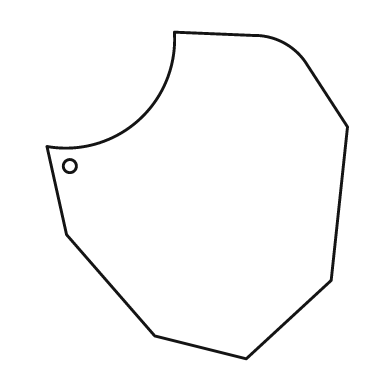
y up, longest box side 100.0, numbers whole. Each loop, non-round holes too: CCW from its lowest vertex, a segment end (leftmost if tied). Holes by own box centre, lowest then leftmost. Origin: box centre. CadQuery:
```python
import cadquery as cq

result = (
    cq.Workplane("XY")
    .moveTo(15.0, -50.0)
    .lineTo(41.0, -26.0)
    .lineTo(46.0, 21.0)
    .lineTo(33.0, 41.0)
    .threePointArc((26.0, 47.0), (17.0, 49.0))
    .lineTo(-7.0, 50.0)
    .threePointArc((-18.0, 23.0), (-46.0, 15.0))
    .lineTo(-40.0, -12.0)
    .lineTo(-13.0, -43.0)
    .close()
    .moveTo(-39.0, 9.0)
    .circle(2.0)
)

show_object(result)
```